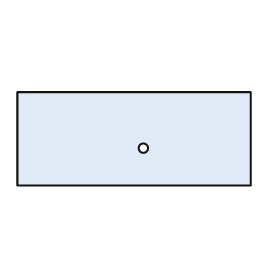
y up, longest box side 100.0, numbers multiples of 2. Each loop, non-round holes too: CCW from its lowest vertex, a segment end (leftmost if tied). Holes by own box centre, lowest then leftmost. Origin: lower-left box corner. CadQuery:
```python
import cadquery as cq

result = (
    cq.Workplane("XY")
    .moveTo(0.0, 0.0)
    .lineTo(100.0, 0.0)
    .lineTo(100.0, 40.0)
    .lineTo(0.0, 40.0)
    .close()
    .moveTo(54.0, 16.0)
    .circle(2.0)
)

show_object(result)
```